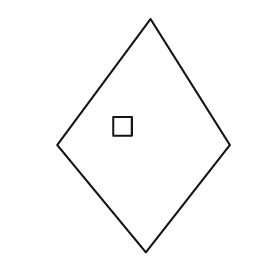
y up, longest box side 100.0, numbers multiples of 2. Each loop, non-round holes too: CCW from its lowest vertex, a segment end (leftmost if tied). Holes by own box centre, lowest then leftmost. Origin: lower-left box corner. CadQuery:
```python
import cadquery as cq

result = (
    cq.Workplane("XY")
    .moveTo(38.0, 0.0)
    .lineTo(74.0, 46.0)
    .lineTo(40.0, 100.0)
    .lineTo(0.0, 46.0)
    .close()
    .moveTo(24.0, 50.0)
    .lineTo(32.0, 50.0)
    .lineTo(32.0, 58.0)
    .lineTo(24.0, 58.0)
    .close()
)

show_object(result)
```